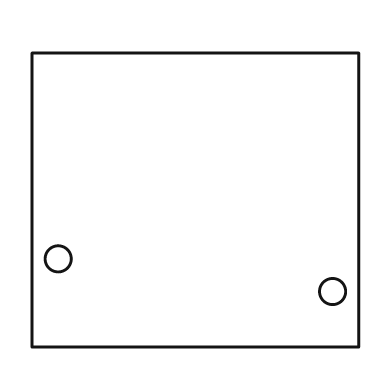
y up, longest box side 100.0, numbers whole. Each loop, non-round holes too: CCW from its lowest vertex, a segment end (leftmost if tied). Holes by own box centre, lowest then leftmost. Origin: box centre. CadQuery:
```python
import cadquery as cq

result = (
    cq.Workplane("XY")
    .moveTo(-50.0, -45.0)
    .lineTo(50.0, -45.0)
    .lineTo(50.0, 45.0)
    .lineTo(-50.0, 45.0)
    .close()
    .moveTo(42.0, -28.0)
    .circle(4.0)
    .moveTo(-42.0, -18.0)
    .circle(4.0)
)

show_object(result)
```